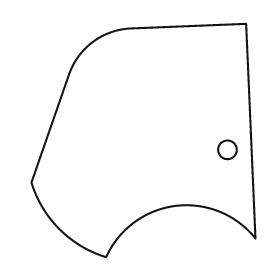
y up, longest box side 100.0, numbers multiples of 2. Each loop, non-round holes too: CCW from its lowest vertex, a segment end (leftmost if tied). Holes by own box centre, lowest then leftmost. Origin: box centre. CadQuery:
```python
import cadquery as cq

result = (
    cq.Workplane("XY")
    .moveTo(-16.0, -50.0)
    .threePointArc((14.0, -28.0), (48.0, -42.0))
    .lineTo(44.0, 50.0)
    .lineTo(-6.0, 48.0)
    .threePointArc((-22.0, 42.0), (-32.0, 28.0))
    .lineTo(-48.0, -18.0)
    .threePointArc((-36.0, -38.0), (-16.0, -50.0))
    .close()
    .moveTo(36.0, -4.0)
    .circle(4.0)
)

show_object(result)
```